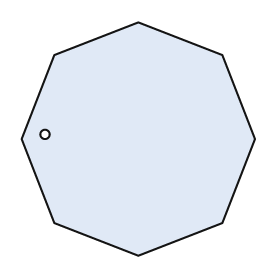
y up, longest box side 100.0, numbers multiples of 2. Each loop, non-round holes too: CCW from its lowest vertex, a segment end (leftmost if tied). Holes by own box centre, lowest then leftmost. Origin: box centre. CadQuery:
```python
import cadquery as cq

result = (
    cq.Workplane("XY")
    .moveTo(0.0, -50.0)
    .lineTo(36.0, -36.0)
    .lineTo(50.0, 0.0)
    .lineTo(36.0, 36.0)
    .lineTo(0.0, 50.0)
    .lineTo(-36.0, 36.0)
    .lineTo(-50.0, 0.0)
    .lineTo(-36.0, -36.0)
    .close()
    .moveTo(-40.0, 2.0)
    .circle(2.0)
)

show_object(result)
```